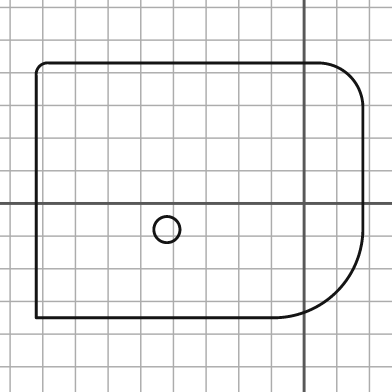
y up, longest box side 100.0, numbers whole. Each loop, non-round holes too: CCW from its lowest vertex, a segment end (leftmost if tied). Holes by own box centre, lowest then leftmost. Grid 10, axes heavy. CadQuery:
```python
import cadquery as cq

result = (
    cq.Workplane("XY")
    .moveTo(-82.0, -35.0)
    .lineTo(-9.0, -35.0)
    .threePointArc((10.0, -27.0), (18.0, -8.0))
    .lineTo(18.0, 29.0)
    .threePointArc((14.0, 39.0), (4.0, 43.0))
    .lineTo(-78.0, 43.0)
    .threePointArc((-81.0, 42.0), (-82.0, 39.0))
    .close()
    .moveTo(-42.0, -8.0)
    .circle(4.0)
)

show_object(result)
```